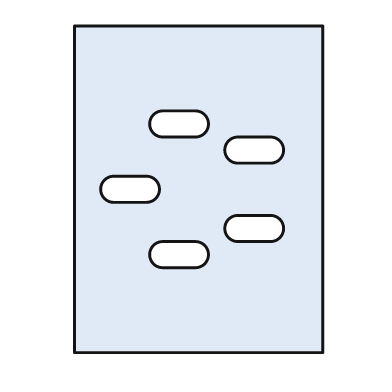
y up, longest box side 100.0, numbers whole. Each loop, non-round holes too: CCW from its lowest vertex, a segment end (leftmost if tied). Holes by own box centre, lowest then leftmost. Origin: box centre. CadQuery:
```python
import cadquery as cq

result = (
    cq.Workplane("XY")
    .moveTo(-38.0, -50.0)
    .lineTo(38.0, -50.0)
    .lineTo(38.0, 50.0)
    .lineTo(-38.0, 50.0)
    .close()
    .moveTo(-11.0, -24.0)
    .lineTo(-1.0, -24.0)
    .threePointArc((3.0, -20.0), (-1.0, -16.0))
    .lineTo(-11.0, -16.0)
    .threePointArc((-15.0, -20.0), (-11.0, -24.0))
    .close()
    .moveTo(12.0, -16.0)
    .lineTo(22.0, -16.0)
    .threePointArc((26.0, -12.0), (22.0, -8.0))
    .lineTo(12.0, -8.0)
    .threePointArc((8.0, -12.0), (12.0, -16.0))
    .close()
    .moveTo(-26.0, -4.0)
    .lineTo(-16.0, -4.0)
    .threePointArc((-12.0, 0.0), (-16.0, 4.0))
    .lineTo(-26.0, 4.0)
    .threePointArc((-30.0, 0.0), (-26.0, -4.0))
    .close()
    .moveTo(12.0, 8.0)
    .lineTo(22.0, 8.0)
    .threePointArc((26.0, 12.0), (22.0, 16.0))
    .lineTo(12.0, 16.0)
    .threePointArc((8.0, 12.0), (12.0, 8.0))
    .close()
    .moveTo(-11.0, 16.0)
    .lineTo(-1.0, 16.0)
    .threePointArc((3.0, 20.0), (-1.0, 24.0))
    .lineTo(-11.0, 24.0)
    .threePointArc((-15.0, 20.0), (-11.0, 16.0))
    .close()
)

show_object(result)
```